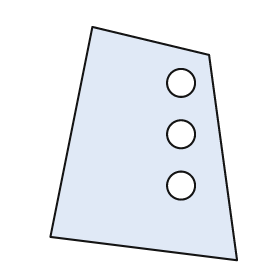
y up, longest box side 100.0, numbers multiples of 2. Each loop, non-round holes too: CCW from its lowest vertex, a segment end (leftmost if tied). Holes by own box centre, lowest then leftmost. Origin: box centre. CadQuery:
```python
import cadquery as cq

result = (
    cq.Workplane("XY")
    .moveTo(40.0, -50.0)
    .lineTo(28.0, 38.0)
    .lineTo(-22.0, 50.0)
    .lineTo(-40.0, -40.0)
    .close()
    .moveTo(16.0, -18.0)
    .circle(6.0)
    .moveTo(16.0, 4.0)
    .circle(6.0)
    .moveTo(16.0, 26.0)
    .circle(6.0)
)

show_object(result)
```